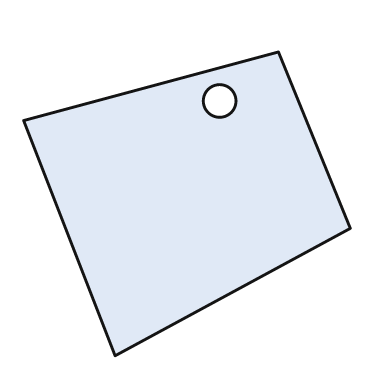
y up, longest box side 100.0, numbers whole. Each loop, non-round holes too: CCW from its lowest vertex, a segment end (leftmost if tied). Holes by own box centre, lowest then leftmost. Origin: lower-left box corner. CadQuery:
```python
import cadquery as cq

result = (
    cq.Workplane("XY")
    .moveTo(28.0, 0.0)
    .lineTo(100.0, 39.0)
    .lineTo(78.0, 93.0)
    .lineTo(0.0, 72.0)
    .close()
    .moveTo(60.0, 78.0)
    .circle(5.0)
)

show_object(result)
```